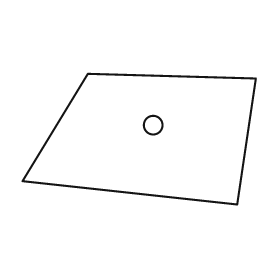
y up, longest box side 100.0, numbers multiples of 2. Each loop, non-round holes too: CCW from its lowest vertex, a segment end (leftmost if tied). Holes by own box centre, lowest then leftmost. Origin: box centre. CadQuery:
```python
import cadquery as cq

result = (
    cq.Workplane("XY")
    .moveTo(42.0, -28.0)
    .lineTo(50.0, 26.0)
    .lineTo(-22.0, 28.0)
    .lineTo(-50.0, -18.0)
    .close()
    .moveTo(6.0, 6.0)
    .circle(4.0)
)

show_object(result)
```